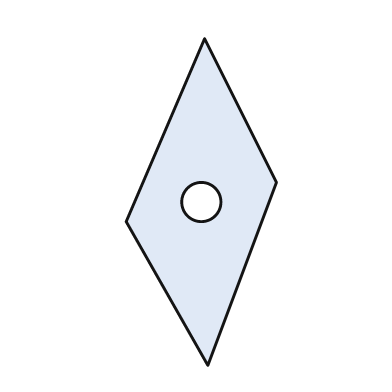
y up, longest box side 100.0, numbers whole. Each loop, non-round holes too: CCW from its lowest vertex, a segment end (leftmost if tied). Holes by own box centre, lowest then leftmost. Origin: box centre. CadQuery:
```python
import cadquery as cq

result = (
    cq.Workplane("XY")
    .moveTo(2.0, -50.0)
    .lineTo(23.0, 6.0)
    .lineTo(1.0, 50.0)
    .lineTo(-23.0, -6.0)
    .close()
    .moveTo(0.0, 0.0)
    .circle(6.0)
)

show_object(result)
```